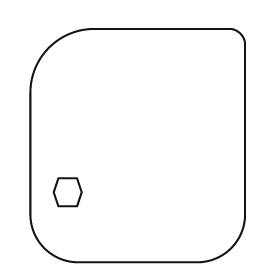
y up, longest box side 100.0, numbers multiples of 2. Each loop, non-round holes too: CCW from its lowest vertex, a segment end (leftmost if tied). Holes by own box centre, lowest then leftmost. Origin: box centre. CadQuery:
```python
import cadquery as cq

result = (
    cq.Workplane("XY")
    .moveTo(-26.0, -50.0)
    .lineTo(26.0, -50.0)
    .threePointArc((40.0, -44.0), (46.0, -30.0))
    .lineTo(46.0, 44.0)
    .threePointArc((44.0, 48.0), (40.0, 50.0))
    .lineTo(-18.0, 50.0)
    .threePointArc((-38.0, 42.0), (-46.0, 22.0))
    .lineTo(-46.0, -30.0)
    .threePointArc((-40.0, -44.0), (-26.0, -50.0))
    .close()
    .moveTo(-34.0, -26.0)
    .lineTo(-26.0, -26.0)
    .lineTo(-24.0, -20.0)
    .lineTo(-26.0, -14.0)
    .lineTo(-34.0, -14.0)
    .lineTo(-36.0, -20.0)
    .close()
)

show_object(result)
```